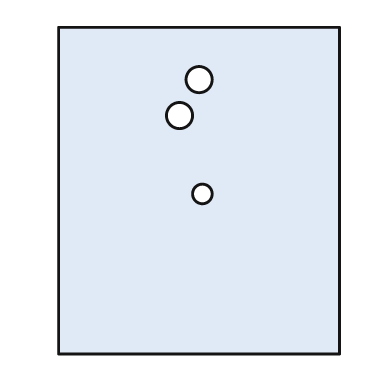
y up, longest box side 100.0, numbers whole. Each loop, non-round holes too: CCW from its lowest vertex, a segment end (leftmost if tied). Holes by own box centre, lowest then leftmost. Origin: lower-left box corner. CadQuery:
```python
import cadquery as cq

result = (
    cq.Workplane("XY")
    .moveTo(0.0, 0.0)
    .lineTo(86.0, 0.0)
    .lineTo(86.0, 100.0)
    .lineTo(0.0, 100.0)
    .close()
    .moveTo(44.0, 49.0)
    .circle(3.0)
    .moveTo(37.0, 73.0)
    .circle(4.0)
    .moveTo(43.0, 84.0)
    .circle(4.0)
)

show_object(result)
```